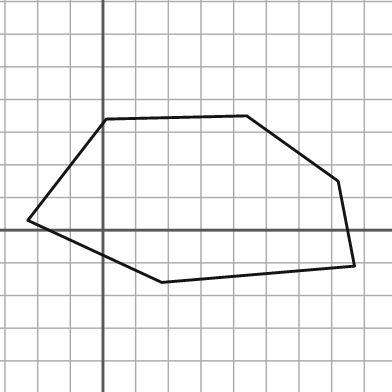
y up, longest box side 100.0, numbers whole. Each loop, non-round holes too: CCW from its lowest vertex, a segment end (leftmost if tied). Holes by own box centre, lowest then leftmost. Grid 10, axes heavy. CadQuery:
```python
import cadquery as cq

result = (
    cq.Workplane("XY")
    .moveTo(18.0, -16.0)
    .lineTo(77.0, -11.0)
    .lineTo(72.0, 15.0)
    .lineTo(44.0, 35.0)
    .lineTo(1.0, 34.0)
    .lineTo(-23.0, 3.0)
    .close()
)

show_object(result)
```